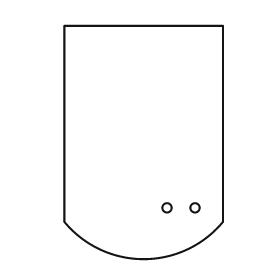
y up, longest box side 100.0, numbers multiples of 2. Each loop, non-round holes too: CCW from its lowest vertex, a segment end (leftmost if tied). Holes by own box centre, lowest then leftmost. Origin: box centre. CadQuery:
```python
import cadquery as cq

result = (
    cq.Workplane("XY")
    .moveTo(-34.0, -34.0)
    .threePointArc((0.0, -50.0), (34.0, -34.0))
    .lineTo(34.0, 50.0)
    .lineTo(-34.0, 50.0)
    .close()
    .moveTo(10.0, -28.0)
    .circle(2.0)
    .moveTo(22.0, -28.0)
    .circle(2.0)
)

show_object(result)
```